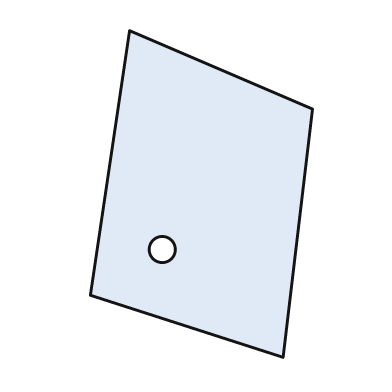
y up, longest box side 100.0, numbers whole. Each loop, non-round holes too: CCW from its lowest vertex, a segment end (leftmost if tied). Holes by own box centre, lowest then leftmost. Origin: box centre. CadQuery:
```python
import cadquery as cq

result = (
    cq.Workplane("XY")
    .moveTo(25.0, -50.0)
    .lineTo(34.0, 26.0)
    .lineTo(-22.0, 50.0)
    .lineTo(-34.0, -31.0)
    .close()
    .moveTo(-12.0, -17.0)
    .circle(4.0)
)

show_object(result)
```